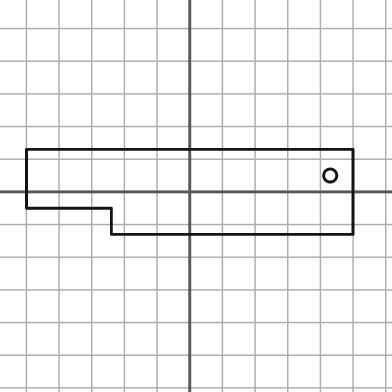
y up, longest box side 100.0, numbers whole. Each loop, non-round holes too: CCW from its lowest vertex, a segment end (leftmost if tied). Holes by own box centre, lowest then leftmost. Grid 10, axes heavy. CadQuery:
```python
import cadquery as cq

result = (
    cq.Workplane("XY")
    .moveTo(-24.0, -13.0)
    .lineTo(50.0, -13.0)
    .lineTo(50.0, 13.0)
    .lineTo(-50.0, 13.0)
    .lineTo(-50.0, -5.0)
    .lineTo(-24.0, -5.0)
    .close()
    .moveTo(43.0, 5.0)
    .circle(2.0)
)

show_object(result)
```